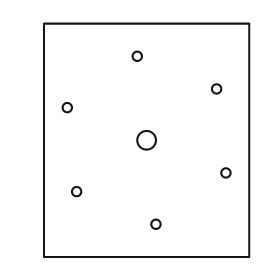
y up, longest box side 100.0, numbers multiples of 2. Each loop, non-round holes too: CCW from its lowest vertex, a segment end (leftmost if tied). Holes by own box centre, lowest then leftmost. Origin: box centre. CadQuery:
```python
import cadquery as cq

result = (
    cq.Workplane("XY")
    .moveTo(-44.0, -50.0)
    .lineTo(44.0, -50.0)
    .lineTo(44.0, 50.0)
    .lineTo(-44.0, 50.0)
    .close()
    .moveTo(4.0, -36.0)
    .circle(2.0)
    .moveTo(-30.0, -22.0)
    .circle(2.0)
    .moveTo(34.0, -14.0)
    .circle(2.0)
    .moveTo(0.0, 0.0)
    .circle(4.0)
    .moveTo(-34.0, 14.0)
    .circle(2.0)
    .moveTo(30.0, 22.0)
    .circle(2.0)
    .moveTo(-4.0, 36.0)
    .circle(2.0)
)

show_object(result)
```